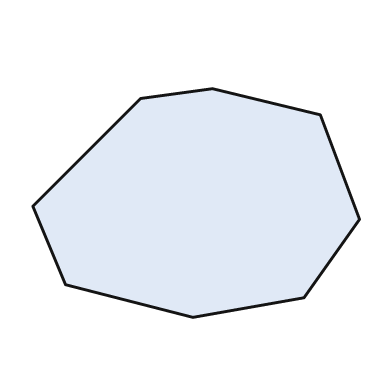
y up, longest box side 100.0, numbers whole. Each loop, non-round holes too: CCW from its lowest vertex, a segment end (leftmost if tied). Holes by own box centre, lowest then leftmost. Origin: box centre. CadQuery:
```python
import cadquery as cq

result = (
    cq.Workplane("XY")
    .moveTo(-1.0, -35.0)
    .lineTo(33.0, -29.0)
    .lineTo(50.0, -5.0)
    .lineTo(38.0, 27.0)
    .lineTo(5.0, 35.0)
    .lineTo(-17.0, 32.0)
    .lineTo(-50.0, -1.0)
    .lineTo(-40.0, -25.0)
    .close()
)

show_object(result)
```